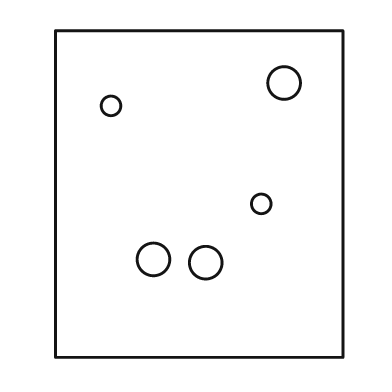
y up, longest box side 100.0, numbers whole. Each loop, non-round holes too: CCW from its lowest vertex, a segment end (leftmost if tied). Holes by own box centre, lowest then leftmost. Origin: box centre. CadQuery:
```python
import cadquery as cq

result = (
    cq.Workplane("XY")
    .moveTo(-44.0, -50.0)
    .lineTo(44.0, -50.0)
    .lineTo(44.0, 50.0)
    .lineTo(-44.0, 50.0)
    .close()
    .moveTo(2.0, -21.0)
    .circle(5.0)
    .moveTo(-14.0, -20.0)
    .circle(5.0)
    .moveTo(19.0, -3.0)
    .circle(3.0)
    .moveTo(-27.0, 27.0)
    .circle(3.0)
    .moveTo(26.0, 34.0)
    .circle(5.0)
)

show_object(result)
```